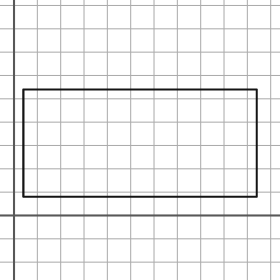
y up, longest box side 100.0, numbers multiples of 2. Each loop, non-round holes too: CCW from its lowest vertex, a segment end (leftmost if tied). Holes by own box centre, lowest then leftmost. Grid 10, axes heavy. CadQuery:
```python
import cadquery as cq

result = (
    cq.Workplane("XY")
    .moveTo(4.0, 8.0)
    .lineTo(104.0, 8.0)
    .lineTo(104.0, 54.0)
    .lineTo(4.0, 54.0)
    .close()
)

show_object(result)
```